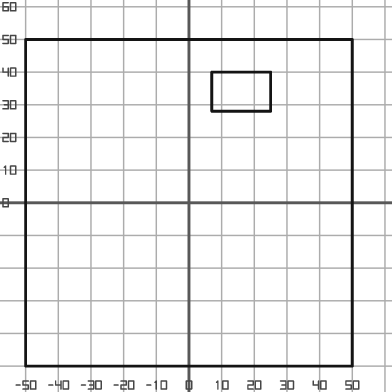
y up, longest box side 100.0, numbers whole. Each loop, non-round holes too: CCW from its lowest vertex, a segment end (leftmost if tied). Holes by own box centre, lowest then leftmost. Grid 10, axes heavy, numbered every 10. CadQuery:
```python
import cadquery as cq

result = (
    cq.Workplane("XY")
    .moveTo(-50.0, -50.0)
    .lineTo(50.0, -50.0)
    .lineTo(50.0, 50.0)
    .lineTo(-50.0, 50.0)
    .close()
    .moveTo(7.0, 28.0)
    .lineTo(25.0, 28.0)
    .lineTo(25.0, 40.0)
    .lineTo(7.0, 40.0)
    .close()
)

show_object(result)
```